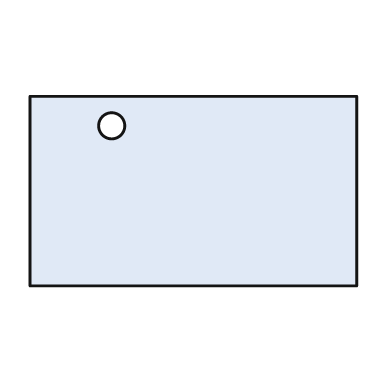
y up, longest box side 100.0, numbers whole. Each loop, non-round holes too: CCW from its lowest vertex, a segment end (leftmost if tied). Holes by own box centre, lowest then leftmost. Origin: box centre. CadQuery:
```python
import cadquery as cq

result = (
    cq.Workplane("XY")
    .moveTo(-50.0, -29.0)
    .lineTo(50.0, -29.0)
    .lineTo(50.0, 29.0)
    .lineTo(-50.0, 29.0)
    .close()
    .moveTo(-25.0, 20.0)
    .circle(4.0)
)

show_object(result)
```